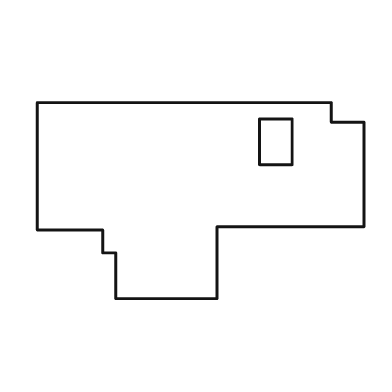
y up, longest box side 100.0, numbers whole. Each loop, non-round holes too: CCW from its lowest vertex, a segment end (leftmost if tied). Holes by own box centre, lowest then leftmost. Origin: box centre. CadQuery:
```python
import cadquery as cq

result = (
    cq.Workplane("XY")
    .moveTo(-26.0, -30.0)
    .lineTo(5.0, -30.0)
    .lineTo(5.0, -8.0)
    .lineTo(50.0, -8.0)
    .lineTo(50.0, 24.0)
    .lineTo(40.0, 24.0)
    .lineTo(40.0, 30.0)
    .lineTo(-50.0, 30.0)
    .lineTo(-50.0, -9.0)
    .lineTo(-30.0, -9.0)
    .lineTo(-30.0, -16.0)
    .lineTo(-26.0, -16.0)
    .close()
    .moveTo(18.0, 11.0)
    .lineTo(28.0, 11.0)
    .lineTo(28.0, 25.0)
    .lineTo(18.0, 25.0)
    .close()
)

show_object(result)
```